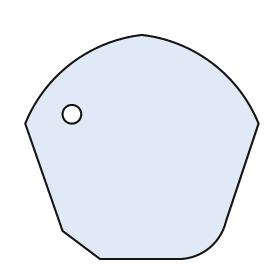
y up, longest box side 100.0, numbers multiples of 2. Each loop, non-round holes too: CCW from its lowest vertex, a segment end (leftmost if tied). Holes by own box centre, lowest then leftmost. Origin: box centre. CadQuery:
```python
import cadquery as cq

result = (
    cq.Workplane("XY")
    .moveTo(-18.0, -48.0)
    .lineTo(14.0, -48.0)
    .threePointArc((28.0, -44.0), (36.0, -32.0))
    .lineTo(50.0, 10.0)
    .threePointArc((30.0, 36.0), (0.0, 48.0))
    .threePointArc((-30.0, 36.0), (-50.0, 10.0))
    .lineTo(-34.0, -36.0)
    .close()
    .moveTo(-30.0, 14.0)
    .circle(4.0)
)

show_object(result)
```